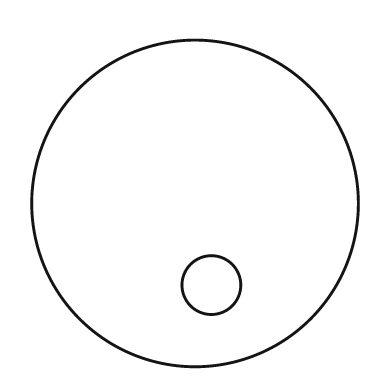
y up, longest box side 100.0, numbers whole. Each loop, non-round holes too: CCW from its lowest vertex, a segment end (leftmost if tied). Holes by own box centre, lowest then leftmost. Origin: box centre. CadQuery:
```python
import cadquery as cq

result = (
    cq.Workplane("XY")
    .moveTo(0.0, 0.0)
    .circle(50.0)
    .moveTo(5.0, -25.0)
    .circle(9.0)
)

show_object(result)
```